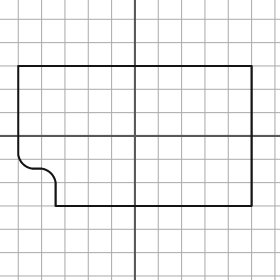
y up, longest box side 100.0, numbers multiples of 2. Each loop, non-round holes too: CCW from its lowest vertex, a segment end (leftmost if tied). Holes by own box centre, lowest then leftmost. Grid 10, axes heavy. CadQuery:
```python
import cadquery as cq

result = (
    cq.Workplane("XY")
    .moveTo(-34.0, -30.0)
    .lineTo(50.0, -30.0)
    .lineTo(50.0, 30.0)
    .lineTo(-50.0, 30.0)
    .lineTo(-50.0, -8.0)
    .threePointArc((-48.0, -12.0), (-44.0, -14.0))
    .lineTo(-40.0, -14.0)
    .threePointArc((-36.0, -16.0), (-34.0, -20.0))
    .close()
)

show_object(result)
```